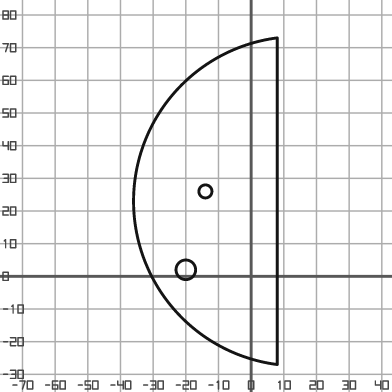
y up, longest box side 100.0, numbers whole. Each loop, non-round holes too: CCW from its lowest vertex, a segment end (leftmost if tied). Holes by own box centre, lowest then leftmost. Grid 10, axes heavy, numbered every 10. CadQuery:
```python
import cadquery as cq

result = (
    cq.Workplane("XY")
    .moveTo(8.0, -27.0)
    .lineTo(8.0, 73.0)
    .threePointArc((-36.0, 23.0), (8.0, -27.0))
    .close()
    .moveTo(-20.0, 2.0)
    .circle(3.0)
    .moveTo(-14.0, 26.0)
    .circle(2.0)
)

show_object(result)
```